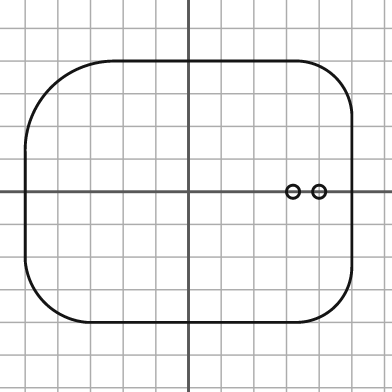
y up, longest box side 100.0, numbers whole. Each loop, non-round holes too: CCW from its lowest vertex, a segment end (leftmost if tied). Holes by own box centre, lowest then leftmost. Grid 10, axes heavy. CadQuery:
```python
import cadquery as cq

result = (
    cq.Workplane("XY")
    .moveTo(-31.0, -40.0)
    .lineTo(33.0, -40.0)
    .threePointArc((45.0, -35.0), (50.0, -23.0))
    .lineTo(50.0, 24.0)
    .threePointArc((45.0, 35.0), (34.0, 40.0))
    .lineTo(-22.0, 40.0)
    .threePointArc((-42.0, 32.0), (-50.0, 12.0))
    .lineTo(-50.0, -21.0)
    .threePointArc((-44.0, -34.0), (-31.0, -40.0))
    .close()
    .moveTo(32.0, 0.0)
    .circle(2.0)
    .moveTo(40.0, 0.0)
    .circle(2.0)
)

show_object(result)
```